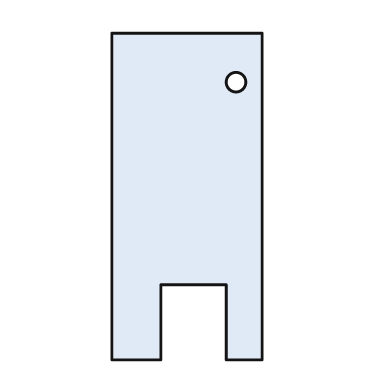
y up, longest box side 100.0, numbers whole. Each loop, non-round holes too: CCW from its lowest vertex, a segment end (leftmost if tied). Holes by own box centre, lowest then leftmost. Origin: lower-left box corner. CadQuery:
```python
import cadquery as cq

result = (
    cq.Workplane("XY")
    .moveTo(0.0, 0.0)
    .lineTo(15.0, 0.0)
    .lineTo(15.0, 23.0)
    .lineTo(35.0, 23.0)
    .lineTo(35.0, 0.0)
    .lineTo(46.0, 0.0)
    .lineTo(46.0, 100.0)
    .lineTo(0.0, 100.0)
    .close()
    .moveTo(38.0, 85.0)
    .circle(3.0)
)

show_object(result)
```